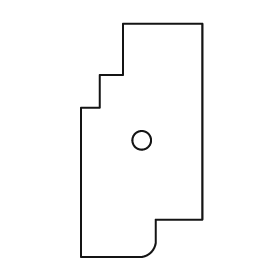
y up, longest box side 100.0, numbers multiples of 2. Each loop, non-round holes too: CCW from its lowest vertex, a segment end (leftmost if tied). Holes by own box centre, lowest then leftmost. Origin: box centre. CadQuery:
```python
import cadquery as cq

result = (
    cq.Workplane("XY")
    .moveTo(-26.0, -50.0)
    .lineTo(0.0, -50.0)
    .threePointArc((4.0, -48.0), (6.0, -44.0))
    .lineTo(6.0, -34.0)
    .lineTo(26.0, -34.0)
    .lineTo(26.0, 50.0)
    .lineTo(-8.0, 50.0)
    .lineTo(-8.0, 28.0)
    .lineTo(-18.0, 28.0)
    .lineTo(-18.0, 14.0)
    .lineTo(-26.0, 14.0)
    .close()
    .moveTo(0.0, 0.0)
    .circle(4.0)
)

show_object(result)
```